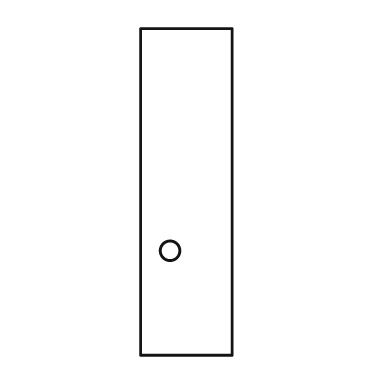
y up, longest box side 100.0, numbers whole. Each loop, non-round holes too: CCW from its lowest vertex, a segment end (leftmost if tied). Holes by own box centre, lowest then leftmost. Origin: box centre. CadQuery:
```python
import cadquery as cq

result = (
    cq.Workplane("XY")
    .moveTo(-14.0, -50.0)
    .lineTo(14.0, -50.0)
    .lineTo(14.0, 50.0)
    .lineTo(-14.0, 50.0)
    .close()
    .moveTo(-5.0, -18.0)
    .circle(3.0)
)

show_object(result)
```